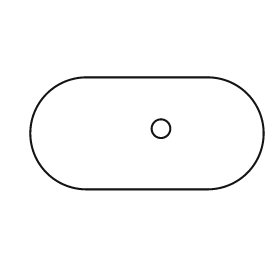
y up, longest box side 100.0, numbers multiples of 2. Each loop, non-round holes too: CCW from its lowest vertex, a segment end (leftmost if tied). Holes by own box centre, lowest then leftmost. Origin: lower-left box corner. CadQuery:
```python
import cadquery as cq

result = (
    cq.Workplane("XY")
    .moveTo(24.0, 0.0)
    .lineTo(76.0, 0.0)
    .threePointArc((100.0, 24.0), (76.0, 48.0))
    .lineTo(24.0, 48.0)
    .threePointArc((0.0, 24.0), (24.0, 0.0))
    .close()
    .moveTo(56.0, 26.0)
    .circle(4.0)
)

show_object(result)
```